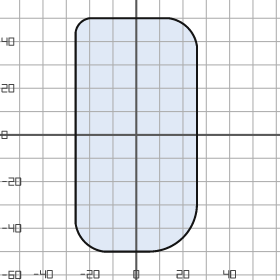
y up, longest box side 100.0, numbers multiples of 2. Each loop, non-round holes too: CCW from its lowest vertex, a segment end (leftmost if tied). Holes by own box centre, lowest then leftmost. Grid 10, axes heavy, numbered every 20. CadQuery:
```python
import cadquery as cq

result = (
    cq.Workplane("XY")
    .moveTo(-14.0, -50.0)
    .lineTo(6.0, -50.0)
    .threePointArc((20.0, -44.0), (26.0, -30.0))
    .lineTo(26.0, 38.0)
    .threePointArc((22.0, 46.0), (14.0, 50.0))
    .lineTo(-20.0, 50.0)
    .threePointArc((-24.0, 48.0), (-26.0, 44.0))
    .lineTo(-26.0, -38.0)
    .threePointArc((-22.0, -46.0), (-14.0, -50.0))
    .close()
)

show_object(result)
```